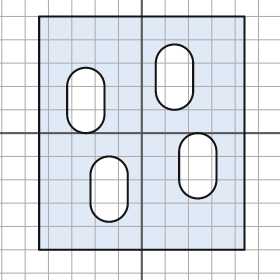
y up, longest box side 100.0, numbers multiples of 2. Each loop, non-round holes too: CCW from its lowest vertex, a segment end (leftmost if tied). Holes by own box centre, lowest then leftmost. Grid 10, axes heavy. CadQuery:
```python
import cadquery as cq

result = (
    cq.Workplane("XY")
    .moveTo(-44.0, -50.0)
    .lineTo(44.0, -50.0)
    .lineTo(44.0, 50.0)
    .lineTo(-44.0, 50.0)
    .close()
    .moveTo(-22.0, -30.0)
    .threePointArc((-14.0, -38.0), (-6.0, -30.0))
    .lineTo(-6.0, -18.0)
    .threePointArc((-14.0, -10.0), (-22.0, -18.0))
    .close()
    .moveTo(16.0, -20.0)
    .threePointArc((24.0, -28.0), (32.0, -20.0))
    .lineTo(32.0, -8.0)
    .threePointArc((24.0, 0.0), (16.0, -8.0))
    .close()
    .moveTo(-32.0, 8.0)
    .threePointArc((-24.0, 0.0), (-16.0, 8.0))
    .lineTo(-16.0, 20.0)
    .threePointArc((-24.0, 28.0), (-32.0, 20.0))
    .close()
    .moveTo(6.0, 18.0)
    .threePointArc((14.0, 10.0), (22.0, 18.0))
    .lineTo(22.0, 30.0)
    .threePointArc((14.0, 38.0), (6.0, 30.0))
    .close()
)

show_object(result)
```